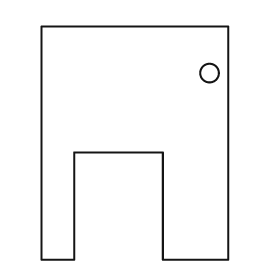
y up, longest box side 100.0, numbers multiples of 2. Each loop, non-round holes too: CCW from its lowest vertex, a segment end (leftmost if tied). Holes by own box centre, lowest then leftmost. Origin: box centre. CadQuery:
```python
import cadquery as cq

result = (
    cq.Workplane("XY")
    .moveTo(-40.0, -50.0)
    .lineTo(-26.0, -50.0)
    .lineTo(-26.0, -4.0)
    .lineTo(12.0, -4.0)
    .lineTo(12.0, -50.0)
    .lineTo(40.0, -50.0)
    .lineTo(40.0, 50.0)
    .lineTo(-40.0, 50.0)
    .close()
    .moveTo(32.0, 30.0)
    .circle(4.0)
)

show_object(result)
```